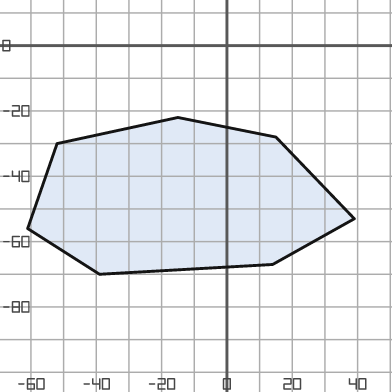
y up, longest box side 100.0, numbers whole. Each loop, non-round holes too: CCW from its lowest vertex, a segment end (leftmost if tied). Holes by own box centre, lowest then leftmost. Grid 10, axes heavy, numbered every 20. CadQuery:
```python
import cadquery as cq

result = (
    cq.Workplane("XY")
    .moveTo(-39.0, -70.0)
    .lineTo(14.0, -67.0)
    .lineTo(39.0, -53.0)
    .lineTo(15.0, -28.0)
    .lineTo(-15.0, -22.0)
    .lineTo(-52.0, -30.0)
    .lineTo(-61.0, -56.0)
    .close()
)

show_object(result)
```